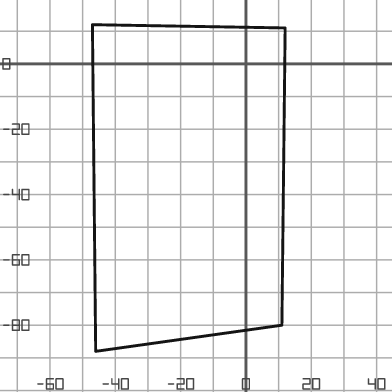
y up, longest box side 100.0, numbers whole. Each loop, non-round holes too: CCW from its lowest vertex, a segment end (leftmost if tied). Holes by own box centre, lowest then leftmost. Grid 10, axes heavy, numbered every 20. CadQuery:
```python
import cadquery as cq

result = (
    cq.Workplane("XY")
    .moveTo(-46.0, -88.0)
    .lineTo(11.0, -80.0)
    .lineTo(12.0, 11.0)
    .lineTo(-47.0, 12.0)
    .close()
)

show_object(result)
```